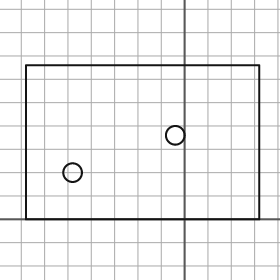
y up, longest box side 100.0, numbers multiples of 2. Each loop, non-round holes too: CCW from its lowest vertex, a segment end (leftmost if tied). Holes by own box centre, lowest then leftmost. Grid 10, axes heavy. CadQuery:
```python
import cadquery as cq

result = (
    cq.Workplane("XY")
    .moveTo(-68.0, 0.0)
    .lineTo(32.0, 0.0)
    .lineTo(32.0, 66.0)
    .lineTo(-68.0, 66.0)
    .close()
    .moveTo(-48.0, 20.0)
    .circle(4.0)
    .moveTo(-4.0, 36.0)
    .circle(4.0)
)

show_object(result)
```